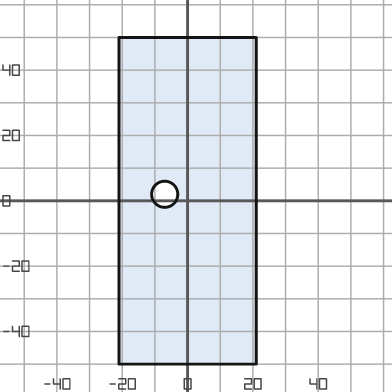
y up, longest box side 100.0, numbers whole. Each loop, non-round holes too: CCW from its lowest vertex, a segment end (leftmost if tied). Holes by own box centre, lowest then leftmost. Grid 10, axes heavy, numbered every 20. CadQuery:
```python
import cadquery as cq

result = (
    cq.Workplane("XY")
    .moveTo(-21.0, -50.0)
    .lineTo(21.0, -50.0)
    .lineTo(21.0, 50.0)
    .lineTo(-21.0, 50.0)
    .close()
    .moveTo(-7.0, 2.0)
    .circle(4.0)
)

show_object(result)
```